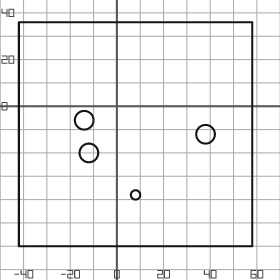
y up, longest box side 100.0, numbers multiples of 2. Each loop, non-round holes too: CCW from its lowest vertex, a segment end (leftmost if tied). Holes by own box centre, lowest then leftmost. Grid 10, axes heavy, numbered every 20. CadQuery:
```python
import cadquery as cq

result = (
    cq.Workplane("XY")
    .moveTo(-42.0, -60.0)
    .lineTo(58.0, -60.0)
    .lineTo(58.0, 36.0)
    .lineTo(-42.0, 36.0)
    .close()
    .moveTo(8.0, -38.0)
    .circle(2.0)
    .moveTo(-12.0, -20.0)
    .circle(4.0)
    .moveTo(38.0, -12.0)
    .circle(4.0)
    .moveTo(-14.0, -6.0)
    .circle(4.0)
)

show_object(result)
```